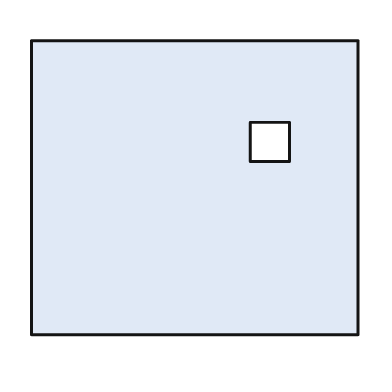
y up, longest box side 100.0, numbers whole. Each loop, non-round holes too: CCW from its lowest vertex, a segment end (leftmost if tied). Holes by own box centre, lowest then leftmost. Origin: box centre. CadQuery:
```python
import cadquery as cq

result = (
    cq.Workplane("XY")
    .moveTo(-50.0, -45.0)
    .lineTo(50.0, -45.0)
    .lineTo(50.0, 45.0)
    .lineTo(-50.0, 45.0)
    .close()
    .moveTo(17.0, 8.0)
    .lineTo(29.0, 8.0)
    .lineTo(29.0, 20.0)
    .lineTo(17.0, 20.0)
    .close()
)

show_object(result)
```